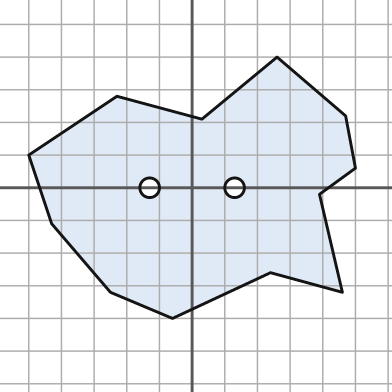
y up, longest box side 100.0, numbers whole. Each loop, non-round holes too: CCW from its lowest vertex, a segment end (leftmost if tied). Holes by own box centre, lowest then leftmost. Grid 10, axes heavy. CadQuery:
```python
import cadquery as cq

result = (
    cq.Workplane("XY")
    .moveTo(-6.0, -40.0)
    .lineTo(24.0, -26.0)
    .lineTo(46.0, -32.0)
    .lineTo(39.0, -2.0)
    .lineTo(50.0, 6.0)
    .lineTo(47.0, 22.0)
    .lineTo(26.0, 40.0)
    .lineTo(3.0, 21.0)
    .lineTo(-23.0, 28.0)
    .lineTo(-50.0, 10.0)
    .lineTo(-43.0, -11.0)
    .lineTo(-25.0, -32.0)
    .close()
    .moveTo(-13.0, 0.0)
    .circle(3.0)
    .moveTo(13.0, 0.0)
    .circle(3.0)
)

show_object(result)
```